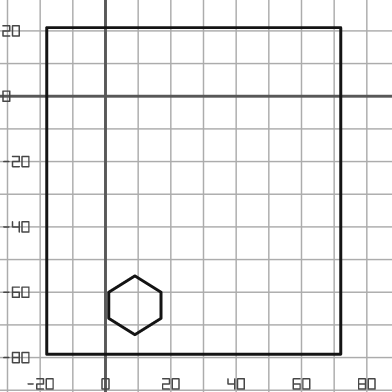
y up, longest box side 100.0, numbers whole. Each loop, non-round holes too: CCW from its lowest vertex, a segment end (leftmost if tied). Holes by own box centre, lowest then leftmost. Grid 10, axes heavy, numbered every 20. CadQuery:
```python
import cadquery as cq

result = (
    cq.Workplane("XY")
    .moveTo(-18.0, -79.0)
    .lineTo(72.0, -79.0)
    .lineTo(72.0, 21.0)
    .lineTo(-18.0, 21.0)
    .close()
    .moveTo(9.0, -73.0)
    .lineTo(17.0, -68.0)
    .lineTo(17.0, -60.0)
    .lineTo(9.0, -55.0)
    .lineTo(1.0, -60.0)
    .lineTo(1.0, -68.0)
    .close()
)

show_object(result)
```